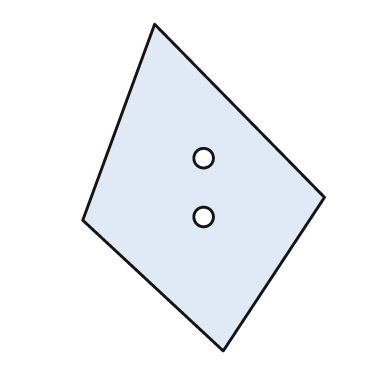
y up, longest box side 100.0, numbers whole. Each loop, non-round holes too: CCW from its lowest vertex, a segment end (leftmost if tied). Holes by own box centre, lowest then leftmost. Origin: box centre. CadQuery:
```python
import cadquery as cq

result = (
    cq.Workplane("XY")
    .moveTo(6.0, -50.0)
    .lineTo(37.0, -3.0)
    .lineTo(-15.0, 50.0)
    .lineTo(-37.0, -10.0)
    .close()
    .moveTo(0.0, -9.0)
    .circle(3.0)
    .moveTo(0.0, 9.0)
    .circle(3.0)
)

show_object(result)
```